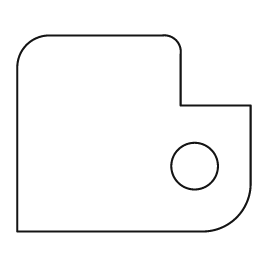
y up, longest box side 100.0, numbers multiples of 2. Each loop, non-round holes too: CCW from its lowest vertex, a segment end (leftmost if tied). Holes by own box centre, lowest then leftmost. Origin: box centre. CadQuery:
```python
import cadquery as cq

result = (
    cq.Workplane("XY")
    .moveTo(-50.0, -42.0)
    .lineTo(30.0, -42.0)
    .threePointArc((44.0, -36.0), (50.0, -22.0))
    .lineTo(50.0, 12.0)
    .lineTo(20.0, 12.0)
    .lineTo(20.0, 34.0)
    .threePointArc((18.0, 40.0), (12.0, 42.0))
    .lineTo(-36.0, 42.0)
    .threePointArc((-46.0, 38.0), (-50.0, 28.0))
    .close()
    .moveTo(26.0, -14.0)
    .circle(10.0)
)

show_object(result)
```